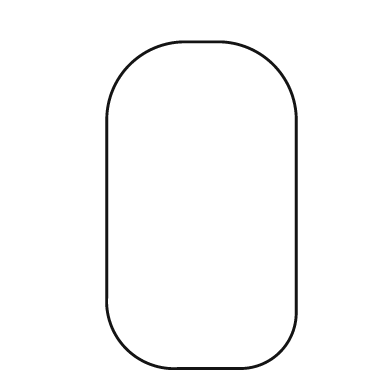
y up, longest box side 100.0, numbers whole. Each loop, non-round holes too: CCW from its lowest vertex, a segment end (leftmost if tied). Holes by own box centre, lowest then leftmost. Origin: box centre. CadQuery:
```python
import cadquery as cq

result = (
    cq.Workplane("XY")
    .moveTo(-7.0, -50.0)
    .lineTo(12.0, -50.0)
    .threePointArc((24.0, -45.0), (29.0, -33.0))
    .lineTo(29.0, 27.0)
    .threePointArc((22.0, 43.0), (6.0, 50.0))
    .lineTo(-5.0, 50.0)
    .threePointArc((-22.0, 43.0), (-29.0, 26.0))
    .lineTo(-29.0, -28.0)
    .threePointArc((-23.0, -44.0), (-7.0, -50.0))
    .close()
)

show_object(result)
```